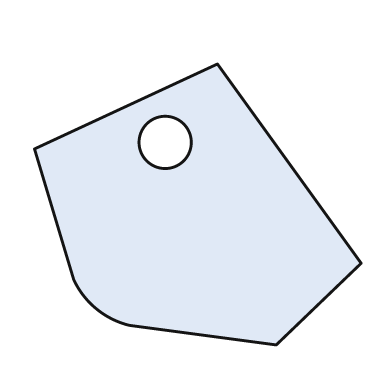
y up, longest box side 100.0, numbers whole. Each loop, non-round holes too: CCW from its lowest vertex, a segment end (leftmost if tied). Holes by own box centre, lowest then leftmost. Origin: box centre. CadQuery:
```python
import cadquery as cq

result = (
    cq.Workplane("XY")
    .moveTo(24.0, -43.0)
    .lineTo(50.0, -18.0)
    .lineTo(6.0, 43.0)
    .lineTo(-50.0, 17.0)
    .lineTo(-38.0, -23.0)
    .threePointArc((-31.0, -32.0), (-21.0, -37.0))
    .close()
    .moveTo(-10.0, 19.0)
    .circle(8.0)
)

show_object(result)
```